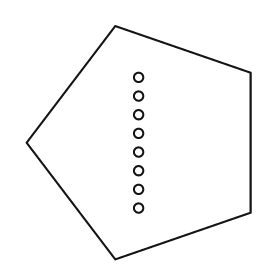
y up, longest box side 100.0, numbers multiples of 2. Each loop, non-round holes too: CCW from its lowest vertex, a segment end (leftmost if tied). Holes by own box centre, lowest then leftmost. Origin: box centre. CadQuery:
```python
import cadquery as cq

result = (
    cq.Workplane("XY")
    .moveTo(-10.0, -50.0)
    .lineTo(48.0, -30.0)
    .lineTo(48.0, 30.0)
    .lineTo(-10.0, 50.0)
    .lineTo(-48.0, 0.0)
    .close()
    .moveTo(0.0, -28.0)
    .circle(2.0)
    .moveTo(0.0, -20.0)
    .circle(2.0)
    .moveTo(0.0, -12.0)
    .circle(2.0)
    .moveTo(0.0, -4.0)
    .circle(2.0)
    .moveTo(0.0, 4.0)
    .circle(2.0)
    .moveTo(0.0, 12.0)
    .circle(2.0)
    .moveTo(0.0, 20.0)
    .circle(2.0)
    .moveTo(0.0, 28.0)
    .circle(2.0)
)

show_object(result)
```